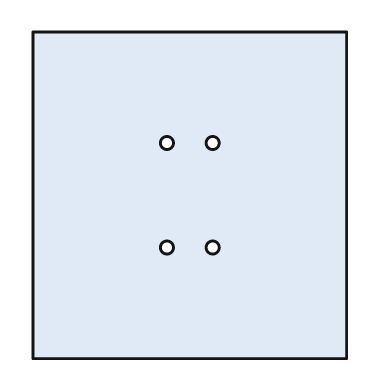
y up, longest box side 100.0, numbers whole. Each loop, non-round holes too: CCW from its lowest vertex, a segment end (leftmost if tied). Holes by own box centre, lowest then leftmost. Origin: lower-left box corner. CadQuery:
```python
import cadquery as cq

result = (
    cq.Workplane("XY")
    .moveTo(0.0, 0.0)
    .lineTo(96.0, 0.0)
    .lineTo(96.0, 100.0)
    .lineTo(0.0, 100.0)
    .close()
    .moveTo(41.0, 34.0)
    .circle(2.0)
    .moveTo(55.0, 34.0)
    .circle(2.0)
    .moveTo(41.0, 66.0)
    .circle(2.0)
    .moveTo(55.0, 66.0)
    .circle(2.0)
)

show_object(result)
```